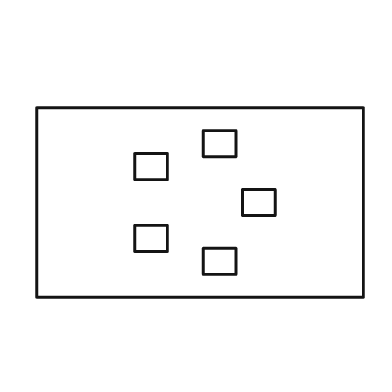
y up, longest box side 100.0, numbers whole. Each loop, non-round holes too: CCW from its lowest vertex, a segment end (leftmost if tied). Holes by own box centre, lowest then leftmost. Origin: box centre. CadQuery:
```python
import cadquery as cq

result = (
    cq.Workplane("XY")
    .moveTo(-50.0, -29.0)
    .lineTo(50.0, -29.0)
    .lineTo(50.0, 29.0)
    .lineTo(-50.0, 29.0)
    .close()
    .moveTo(1.0, -22.0)
    .lineTo(11.0, -22.0)
    .lineTo(11.0, -14.0)
    .lineTo(1.0, -14.0)
    .close()
    .moveTo(-20.0, -15.0)
    .lineTo(-10.0, -15.0)
    .lineTo(-10.0, -7.0)
    .lineTo(-20.0, -7.0)
    .close()
    .moveTo(13.0, -4.0)
    .lineTo(23.0, -4.0)
    .lineTo(23.0, 4.0)
    .lineTo(13.0, 4.0)
    .close()
    .moveTo(-20.0, 7.0)
    .lineTo(-10.0, 7.0)
    .lineTo(-10.0, 15.0)
    .lineTo(-20.0, 15.0)
    .close()
    .moveTo(1.0, 14.0)
    .lineTo(11.0, 14.0)
    .lineTo(11.0, 22.0)
    .lineTo(1.0, 22.0)
    .close()
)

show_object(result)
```